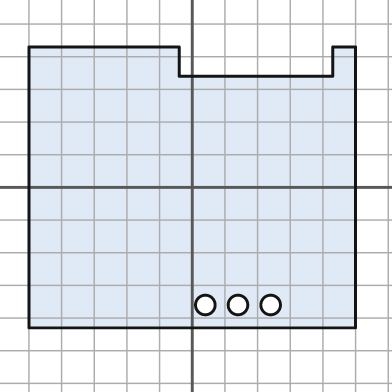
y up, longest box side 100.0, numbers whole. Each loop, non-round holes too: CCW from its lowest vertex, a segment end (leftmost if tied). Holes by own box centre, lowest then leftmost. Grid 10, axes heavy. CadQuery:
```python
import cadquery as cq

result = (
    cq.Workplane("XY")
    .moveTo(-50.0, -43.0)
    .lineTo(50.0, -43.0)
    .lineTo(50.0, 43.0)
    .lineTo(43.0, 43.0)
    .lineTo(43.0, 34.0)
    .lineTo(-4.0, 34.0)
    .lineTo(-4.0, 43.0)
    .lineTo(-50.0, 43.0)
    .close()
    .moveTo(4.0, -36.0)
    .circle(3.0)
    .moveTo(14.0, -36.0)
    .circle(3.0)
    .moveTo(24.0, -36.0)
    .circle(3.0)
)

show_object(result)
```